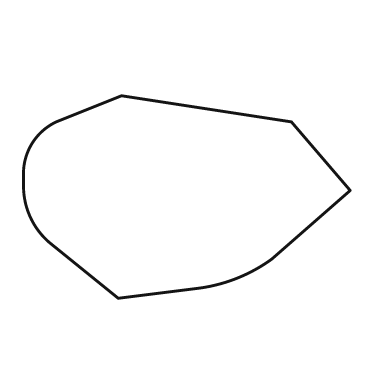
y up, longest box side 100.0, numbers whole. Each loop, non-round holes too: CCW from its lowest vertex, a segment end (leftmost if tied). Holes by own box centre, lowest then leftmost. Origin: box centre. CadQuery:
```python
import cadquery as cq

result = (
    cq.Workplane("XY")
    .moveTo(-21.0, -31.0)
    .lineTo(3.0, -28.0)
    .threePointArc((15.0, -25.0), (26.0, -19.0))
    .lineTo(50.0, 2.0)
    .lineTo(32.0, 23.0)
    .lineTo(-20.0, 31.0)
    .lineTo(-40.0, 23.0)
    .threePointArc((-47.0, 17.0), (-50.0, 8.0))
    .lineTo(-50.0, 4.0)
    .threePointArc((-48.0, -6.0), (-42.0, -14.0))
    .close()
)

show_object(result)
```